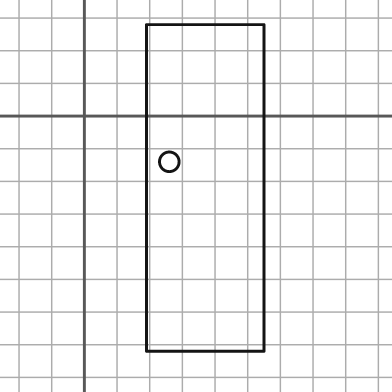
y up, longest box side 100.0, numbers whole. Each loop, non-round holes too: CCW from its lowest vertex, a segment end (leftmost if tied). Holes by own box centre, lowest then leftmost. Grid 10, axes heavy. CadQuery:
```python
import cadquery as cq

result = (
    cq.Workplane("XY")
    .moveTo(19.0, -72.0)
    .lineTo(55.0, -72.0)
    .lineTo(55.0, 28.0)
    .lineTo(19.0, 28.0)
    .close()
    .moveTo(26.0, -14.0)
    .circle(3.0)
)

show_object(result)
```